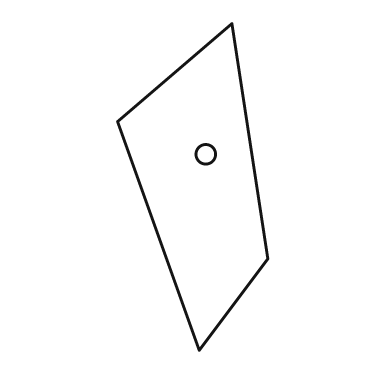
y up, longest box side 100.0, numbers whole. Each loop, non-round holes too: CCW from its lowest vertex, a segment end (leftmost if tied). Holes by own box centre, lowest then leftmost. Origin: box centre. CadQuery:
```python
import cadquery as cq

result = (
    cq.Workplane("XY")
    .moveTo(2.0, -50.0)
    .lineTo(23.0, -22.0)
    .lineTo(12.0, 50.0)
    .lineTo(-23.0, 20.0)
    .close()
    .moveTo(4.0, 10.0)
    .circle(3.0)
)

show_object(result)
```